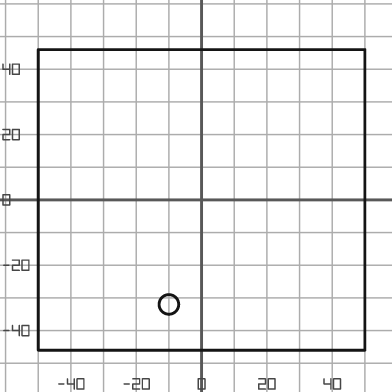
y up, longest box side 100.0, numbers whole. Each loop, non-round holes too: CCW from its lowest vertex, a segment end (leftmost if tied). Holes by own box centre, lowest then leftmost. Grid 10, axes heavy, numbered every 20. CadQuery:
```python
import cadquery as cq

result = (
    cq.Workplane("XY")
    .moveTo(-50.0, -46.0)
    .lineTo(50.0, -46.0)
    .lineTo(50.0, 46.0)
    .lineTo(-50.0, 46.0)
    .close()
    .moveTo(-10.0, -32.0)
    .circle(3.0)
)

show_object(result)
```